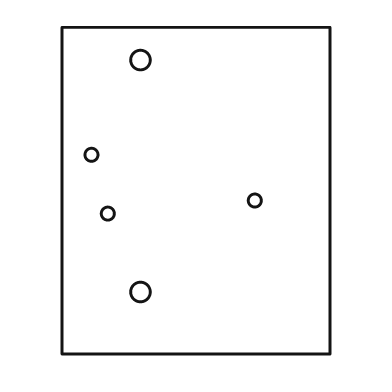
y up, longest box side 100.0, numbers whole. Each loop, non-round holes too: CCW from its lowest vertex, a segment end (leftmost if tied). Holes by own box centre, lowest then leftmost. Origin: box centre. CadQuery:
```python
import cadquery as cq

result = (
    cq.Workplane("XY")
    .moveTo(-41.0, -50.0)
    .lineTo(41.0, -50.0)
    .lineTo(41.0, 50.0)
    .lineTo(-41.0, 50.0)
    .close()
    .moveTo(-17.0, -31.0)
    .circle(3.0)
    .moveTo(-27.0, -7.0)
    .circle(2.0)
    .moveTo(18.0, -3.0)
    .circle(2.0)
    .moveTo(-32.0, 11.0)
    .circle(2.0)
    .moveTo(-17.0, 40.0)
    .circle(3.0)
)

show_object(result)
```